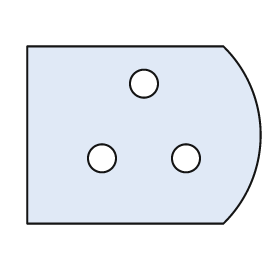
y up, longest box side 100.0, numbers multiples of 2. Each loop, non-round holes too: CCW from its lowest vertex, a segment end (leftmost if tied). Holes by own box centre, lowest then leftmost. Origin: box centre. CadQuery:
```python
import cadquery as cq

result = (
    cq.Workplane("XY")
    .moveTo(-50.0, -38.0)
    .lineTo(34.0, -38.0)
    .threePointArc((50.0, 0.0), (34.0, 38.0))
    .lineTo(-50.0, 38.0)
    .close()
    .moveTo(-18.0, -10.0)
    .circle(6.0)
    .moveTo(18.0, -10.0)
    .circle(6.0)
    .moveTo(0.0, 22.0)
    .circle(6.0)
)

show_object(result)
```